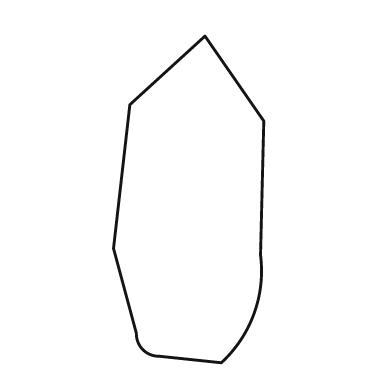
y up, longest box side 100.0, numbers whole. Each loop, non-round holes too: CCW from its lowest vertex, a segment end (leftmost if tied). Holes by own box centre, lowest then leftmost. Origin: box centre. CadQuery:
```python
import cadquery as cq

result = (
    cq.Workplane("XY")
    .moveTo(10.0, -50.0)
    .threePointArc((20.0, -35.0), (22.0, -17.0))
    .lineTo(23.0, 24.0)
    .lineTo(5.0, 50.0)
    .lineTo(-18.0, 29.0)
    .lineTo(-23.0, -15.0)
    .lineTo(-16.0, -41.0)
    .threePointArc((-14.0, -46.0), (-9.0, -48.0))
    .close()
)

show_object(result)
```